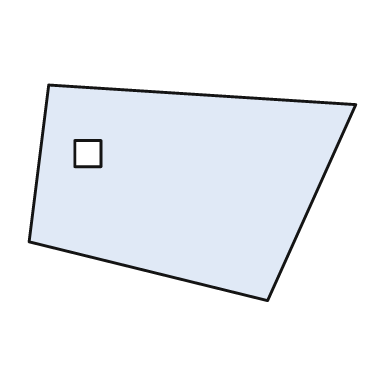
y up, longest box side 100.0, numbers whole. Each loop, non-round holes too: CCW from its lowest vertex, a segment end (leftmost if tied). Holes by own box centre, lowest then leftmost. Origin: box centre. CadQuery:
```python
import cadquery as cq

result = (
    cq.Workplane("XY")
    .moveTo(23.0, -33.0)
    .lineTo(50.0, 27.0)
    .lineTo(-44.0, 33.0)
    .lineTo(-50.0, -15.0)
    .close()
    .moveTo(-36.0, 8.0)
    .lineTo(-28.0, 8.0)
    .lineTo(-28.0, 16.0)
    .lineTo(-36.0, 16.0)
    .close()
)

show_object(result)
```